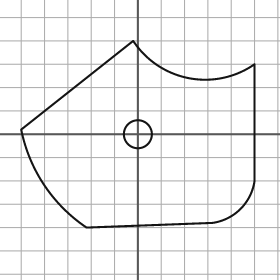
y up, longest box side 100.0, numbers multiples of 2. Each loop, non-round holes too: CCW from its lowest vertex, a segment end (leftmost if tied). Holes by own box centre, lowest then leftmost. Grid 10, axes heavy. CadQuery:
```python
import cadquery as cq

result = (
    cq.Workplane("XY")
    .moveTo(-22.0, -40.0)
    .lineTo(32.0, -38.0)
    .threePointArc((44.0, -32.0), (50.0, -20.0))
    .lineTo(50.0, 30.0)
    .threePointArc((22.0, 24.0), (-2.0, 40.0))
    .lineTo(-50.0, 2.0)
    .threePointArc((-40.0, -22.0), (-22.0, -40.0))
    .close()
    .moveTo(0.0, 0.0)
    .circle(6.0)
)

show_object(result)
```